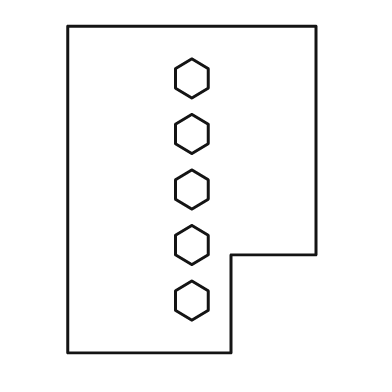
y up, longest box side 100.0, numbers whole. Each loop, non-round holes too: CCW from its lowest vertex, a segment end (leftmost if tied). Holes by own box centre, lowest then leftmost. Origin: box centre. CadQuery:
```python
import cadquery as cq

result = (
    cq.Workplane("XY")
    .moveTo(-38.0, -50.0)
    .lineTo(12.0, -50.0)
    .lineTo(12.0, -20.0)
    .lineTo(38.0, -20.0)
    .lineTo(38.0, 50.0)
    .lineTo(-38.0, 50.0)
    .close()
    .moveTo(0.0, -40.0)
    .lineTo(5.0, -37.0)
    .lineTo(5.0, -31.0)
    .lineTo(0.0, -28.0)
    .lineTo(-5.0, -31.0)
    .lineTo(-5.0, -37.0)
    .close()
    .moveTo(0.0, -23.0)
    .lineTo(5.0, -20.0)
    .lineTo(5.0, -14.0)
    .lineTo(0.0, -11.0)
    .lineTo(-5.0, -14.0)
    .lineTo(-5.0, -20.0)
    .close()
    .moveTo(0.0, -6.0)
    .lineTo(5.0, -3.0)
    .lineTo(5.0, 3.0)
    .lineTo(0.0, 6.0)
    .lineTo(-5.0, 3.0)
    .lineTo(-5.0, -3.0)
    .close()
    .moveTo(0.0, 11.0)
    .lineTo(5.0, 14.0)
    .lineTo(5.0, 20.0)
    .lineTo(0.0, 23.0)
    .lineTo(-5.0, 20.0)
    .lineTo(-5.0, 14.0)
    .close()
    .moveTo(0.0, 28.0)
    .lineTo(5.0, 31.0)
    .lineTo(5.0, 37.0)
    .lineTo(0.0, 40.0)
    .lineTo(-5.0, 37.0)
    .lineTo(-5.0, 31.0)
    .close()
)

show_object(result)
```